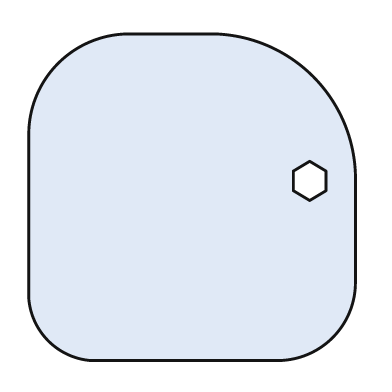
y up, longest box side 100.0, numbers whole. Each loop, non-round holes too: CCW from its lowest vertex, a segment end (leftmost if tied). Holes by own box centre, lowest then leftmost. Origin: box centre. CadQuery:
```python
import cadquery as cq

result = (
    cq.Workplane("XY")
    .moveTo(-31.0, -50.0)
    .lineTo(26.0, -50.0)
    .threePointArc((43.0, -43.0), (50.0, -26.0))
    .lineTo(50.0, 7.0)
    .threePointArc((37.0, 37.0), (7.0, 50.0))
    .lineTo(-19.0, 50.0)
    .threePointArc((-41.0, 41.0), (-50.0, 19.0))
    .lineTo(-50.0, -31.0)
    .threePointArc((-44.0, -44.0), (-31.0, -50.0))
    .close()
    .moveTo(36.0, -1.0)
    .lineTo(41.0, 2.0)
    .lineTo(41.0, 8.0)
    .lineTo(36.0, 11.0)
    .lineTo(31.0, 8.0)
    .lineTo(31.0, 2.0)
    .close()
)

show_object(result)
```